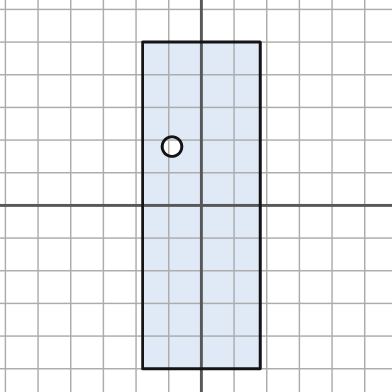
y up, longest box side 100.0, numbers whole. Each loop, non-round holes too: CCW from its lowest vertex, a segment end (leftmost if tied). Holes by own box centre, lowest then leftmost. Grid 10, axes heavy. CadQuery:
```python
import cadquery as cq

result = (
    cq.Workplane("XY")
    .moveTo(-18.0, -50.0)
    .lineTo(18.0, -50.0)
    .lineTo(18.0, 50.0)
    .lineTo(-18.0, 50.0)
    .close()
    .moveTo(-9.0, 18.0)
    .circle(3.0)
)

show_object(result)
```